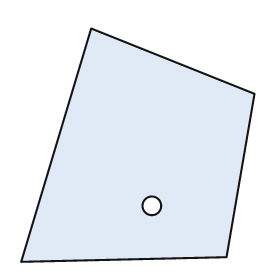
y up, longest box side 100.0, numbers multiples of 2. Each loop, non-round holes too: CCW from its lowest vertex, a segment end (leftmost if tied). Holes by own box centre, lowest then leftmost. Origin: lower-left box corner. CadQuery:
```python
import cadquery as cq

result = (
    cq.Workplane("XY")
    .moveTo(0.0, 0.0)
    .lineTo(88.0, 2.0)
    .lineTo(100.0, 72.0)
    .lineTo(30.0, 100.0)
    .close()
    .moveTo(56.0, 24.0)
    .circle(4.0)
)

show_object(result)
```